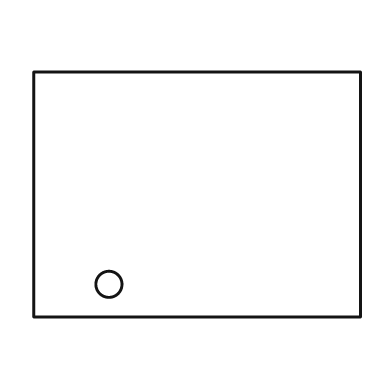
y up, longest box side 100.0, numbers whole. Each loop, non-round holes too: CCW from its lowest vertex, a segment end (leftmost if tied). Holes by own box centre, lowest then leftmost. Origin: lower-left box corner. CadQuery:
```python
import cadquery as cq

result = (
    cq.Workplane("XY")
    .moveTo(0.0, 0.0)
    .lineTo(100.0, 0.0)
    .lineTo(100.0, 75.0)
    .lineTo(0.0, 75.0)
    .close()
    .moveTo(23.0, 10.0)
    .circle(4.0)
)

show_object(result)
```